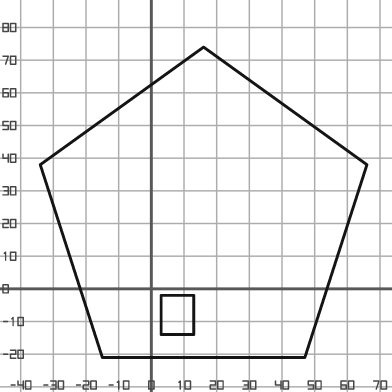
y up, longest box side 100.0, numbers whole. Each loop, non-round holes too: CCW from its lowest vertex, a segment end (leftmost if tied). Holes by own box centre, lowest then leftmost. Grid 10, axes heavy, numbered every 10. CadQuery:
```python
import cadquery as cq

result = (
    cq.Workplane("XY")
    .moveTo(-15.0, -21.0)
    .lineTo(47.0, -21.0)
    .lineTo(66.0, 38.0)
    .lineTo(16.0, 74.0)
    .lineTo(-34.0, 38.0)
    .close()
    .moveTo(3.0, -14.0)
    .lineTo(13.0, -14.0)
    .lineTo(13.0, -2.0)
    .lineTo(3.0, -2.0)
    .close()
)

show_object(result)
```